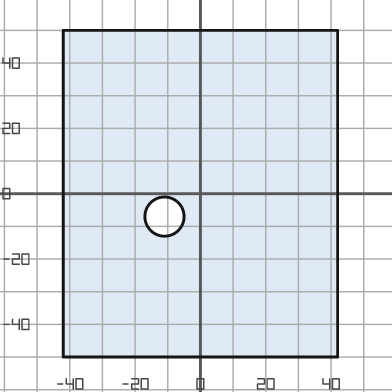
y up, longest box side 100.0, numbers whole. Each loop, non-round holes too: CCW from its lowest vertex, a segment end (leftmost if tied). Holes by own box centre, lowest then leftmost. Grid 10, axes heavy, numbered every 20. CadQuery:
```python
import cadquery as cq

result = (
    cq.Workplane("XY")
    .moveTo(-42.0, -50.0)
    .lineTo(42.0, -50.0)
    .lineTo(42.0, 50.0)
    .lineTo(-42.0, 50.0)
    .close()
    .moveTo(-11.0, -7.0)
    .circle(6.0)
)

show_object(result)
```